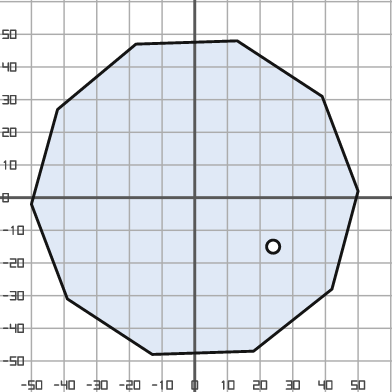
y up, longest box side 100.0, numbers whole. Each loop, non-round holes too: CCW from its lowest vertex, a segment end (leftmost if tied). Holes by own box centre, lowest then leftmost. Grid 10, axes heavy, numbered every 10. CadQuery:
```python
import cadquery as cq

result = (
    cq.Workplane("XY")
    .moveTo(-13.0, -48.0)
    .lineTo(18.0, -47.0)
    .lineTo(42.0, -28.0)
    .lineTo(50.0, 2.0)
    .lineTo(39.0, 31.0)
    .lineTo(13.0, 48.0)
    .lineTo(-18.0, 47.0)
    .lineTo(-42.0, 27.0)
    .lineTo(-50.0, -2.0)
    .lineTo(-39.0, -31.0)
    .close()
    .moveTo(24.0, -15.0)
    .circle(2.0)
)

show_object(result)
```